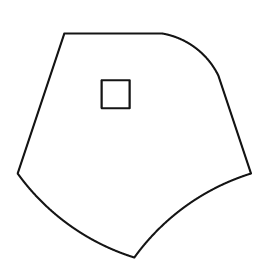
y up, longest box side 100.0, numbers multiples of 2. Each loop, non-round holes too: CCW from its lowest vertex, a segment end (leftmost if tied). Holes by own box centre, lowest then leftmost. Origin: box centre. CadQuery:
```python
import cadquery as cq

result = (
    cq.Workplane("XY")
    .moveTo(0.0, -48.0)
    .threePointArc((22.0, -26.0), (50.0, -12.0))
    .lineTo(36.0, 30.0)
    .threePointArc((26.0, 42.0), (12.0, 48.0))
    .lineTo(-30.0, 48.0)
    .lineTo(-50.0, -12.0)
    .threePointArc((-28.0, -34.0), (0.0, -48.0))
    .close()
    .moveTo(-14.0, 16.0)
    .lineTo(-2.0, 16.0)
    .lineTo(-2.0, 28.0)
    .lineTo(-14.0, 28.0)
    .close()
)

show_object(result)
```